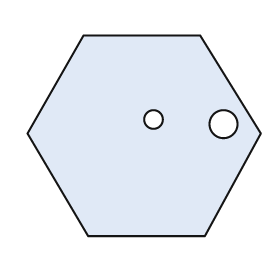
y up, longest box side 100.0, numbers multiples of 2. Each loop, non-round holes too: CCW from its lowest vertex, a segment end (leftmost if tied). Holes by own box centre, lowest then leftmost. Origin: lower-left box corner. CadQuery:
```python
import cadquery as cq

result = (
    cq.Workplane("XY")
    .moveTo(26.0, 0.0)
    .lineTo(76.0, 0.0)
    .lineTo(100.0, 44.0)
    .lineTo(74.0, 86.0)
    .lineTo(24.0, 86.0)
    .lineTo(0.0, 44.0)
    .close()
    .moveTo(84.0, 48.0)
    .circle(6.0)
    .moveTo(54.0, 50.0)
    .circle(4.0)
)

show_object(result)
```